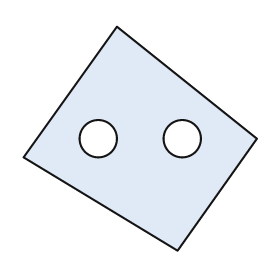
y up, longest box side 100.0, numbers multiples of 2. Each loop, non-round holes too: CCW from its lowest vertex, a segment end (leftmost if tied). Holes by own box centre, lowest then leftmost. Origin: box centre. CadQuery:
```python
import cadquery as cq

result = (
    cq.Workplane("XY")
    .moveTo(16.0, -48.0)
    .lineTo(50.0, 0.0)
    .lineTo(-10.0, 48.0)
    .lineTo(-50.0, -8.0)
    .close()
    .moveTo(-18.0, 0.0)
    .circle(8.0)
    .moveTo(18.0, 0.0)
    .circle(8.0)
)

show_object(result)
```